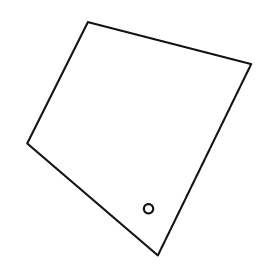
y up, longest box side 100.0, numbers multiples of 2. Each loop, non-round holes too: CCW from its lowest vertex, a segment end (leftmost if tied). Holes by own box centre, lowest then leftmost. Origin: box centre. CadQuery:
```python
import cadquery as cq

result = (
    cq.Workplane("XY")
    .moveTo(8.0, -50.0)
    .lineTo(48.0, 32.0)
    .lineTo(-22.0, 50.0)
    .lineTo(-48.0, -2.0)
    .close()
    .moveTo(4.0, -30.0)
    .circle(2.0)
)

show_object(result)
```